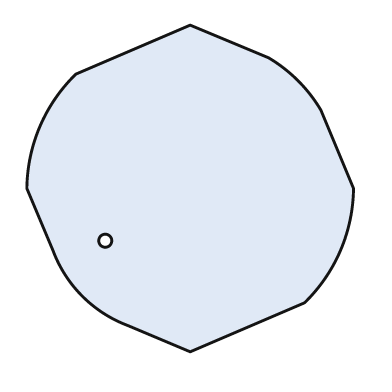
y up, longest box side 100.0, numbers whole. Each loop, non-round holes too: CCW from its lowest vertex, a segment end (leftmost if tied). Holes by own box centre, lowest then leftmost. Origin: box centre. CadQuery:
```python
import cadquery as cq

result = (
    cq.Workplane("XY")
    .moveTo(0.0, -50.0)
    .lineTo(35.0, -35.0)
    .threePointArc((46.0, -19.0), (50.0, 0.0))
    .lineTo(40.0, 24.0)
    .threePointArc((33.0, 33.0), (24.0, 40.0))
    .lineTo(0.0, 50.0)
    .lineTo(-35.0, 35.0)
    .threePointArc((-46.0, 19.0), (-50.0, 0.0))
    .lineTo(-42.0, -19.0)
    .threePointArc((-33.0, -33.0), (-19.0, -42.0))
    .close()
    .moveTo(-26.0, -16.0)
    .circle(2.0)
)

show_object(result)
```